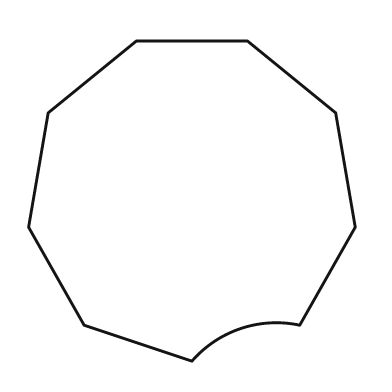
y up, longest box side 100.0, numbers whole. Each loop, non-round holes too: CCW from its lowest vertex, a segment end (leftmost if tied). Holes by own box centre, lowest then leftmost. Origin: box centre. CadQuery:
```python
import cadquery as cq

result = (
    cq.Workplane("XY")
    .moveTo(0.0, -49.0)
    .threePointArc((15.0, -39.0), (33.0, -38.0))
    .lineTo(50.0, -8.0)
    .lineTo(44.0, 27.0)
    .lineTo(17.0, 49.0)
    .lineTo(-17.0, 49.0)
    .lineTo(-44.0, 27.0)
    .lineTo(-50.0, -8.0)
    .lineTo(-33.0, -38.0)
    .close()
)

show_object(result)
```